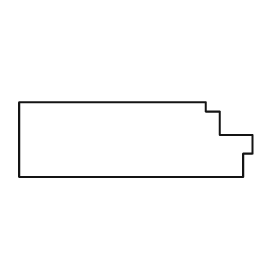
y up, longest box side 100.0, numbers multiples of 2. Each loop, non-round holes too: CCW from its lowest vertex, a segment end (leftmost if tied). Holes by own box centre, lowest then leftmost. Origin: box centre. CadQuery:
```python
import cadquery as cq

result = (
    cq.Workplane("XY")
    .moveTo(-50.0, -16.0)
    .lineTo(46.0, -16.0)
    .lineTo(46.0, -6.0)
    .lineTo(50.0, -6.0)
    .lineTo(50.0, 2.0)
    .lineTo(36.0, 2.0)
    .lineTo(36.0, 12.0)
    .lineTo(30.0, 12.0)
    .lineTo(30.0, 16.0)
    .lineTo(-50.0, 16.0)
    .close()
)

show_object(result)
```